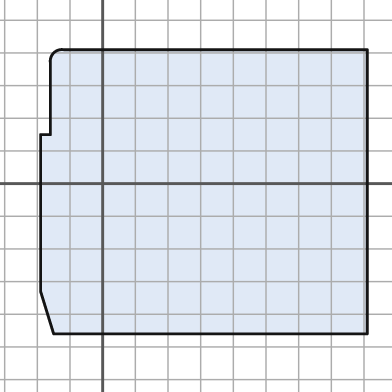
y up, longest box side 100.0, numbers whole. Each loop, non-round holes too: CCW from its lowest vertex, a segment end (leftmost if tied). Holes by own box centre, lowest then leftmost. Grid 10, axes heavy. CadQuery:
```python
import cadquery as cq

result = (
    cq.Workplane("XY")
    .moveTo(-15.0, -46.0)
    .lineTo(81.0, -46.0)
    .lineTo(81.0, 41.0)
    .lineTo(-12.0, 41.0)
    .threePointArc((-15.0, 40.0), (-16.0, 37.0))
    .lineTo(-16.0, 15.0)
    .lineTo(-19.0, 15.0)
    .lineTo(-19.0, -33.0)
    .close()
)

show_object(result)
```